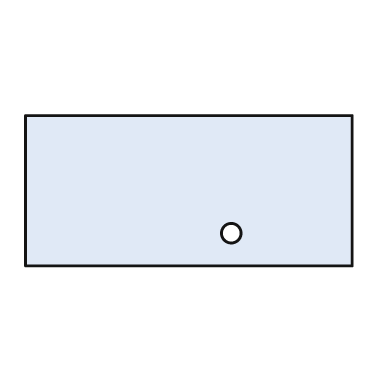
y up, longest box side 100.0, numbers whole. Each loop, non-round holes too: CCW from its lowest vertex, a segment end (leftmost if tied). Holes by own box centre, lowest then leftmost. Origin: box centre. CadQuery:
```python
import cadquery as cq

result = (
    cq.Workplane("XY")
    .moveTo(-50.0, -23.0)
    .lineTo(50.0, -23.0)
    .lineTo(50.0, 23.0)
    .lineTo(-50.0, 23.0)
    .close()
    .moveTo(13.0, -13.0)
    .circle(3.0)
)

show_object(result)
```